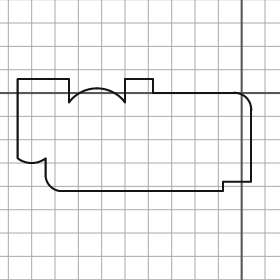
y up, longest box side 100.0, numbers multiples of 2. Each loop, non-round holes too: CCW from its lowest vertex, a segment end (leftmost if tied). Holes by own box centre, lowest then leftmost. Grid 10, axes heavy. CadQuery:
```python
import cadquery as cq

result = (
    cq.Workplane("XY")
    .moveTo(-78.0, -42.0)
    .lineTo(-8.0, -42.0)
    .lineTo(-8.0, -38.0)
    .lineTo(4.0, -38.0)
    .lineTo(4.0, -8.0)
    .threePointArc((2.0, -2.0), (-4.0, 0.0))
    .lineTo(-38.0, 0.0)
    .lineTo(-38.0, 6.0)
    .lineTo(-50.0, 6.0)
    .lineTo(-50.0, -4.0)
    .threePointArc((-62.0, 2.0), (-74.0, -4.0))
    .lineTo(-74.0, 6.0)
    .lineTo(-96.0, 6.0)
    .lineTo(-96.0, -28.0)
    .threePointArc((-90.0, -30.0), (-84.0, -28.0))
    .lineTo(-84.0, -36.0)
    .threePointArc((-82.0, -40.0), (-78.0, -42.0))
    .close()
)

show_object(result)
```